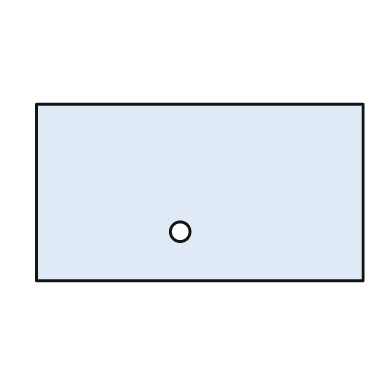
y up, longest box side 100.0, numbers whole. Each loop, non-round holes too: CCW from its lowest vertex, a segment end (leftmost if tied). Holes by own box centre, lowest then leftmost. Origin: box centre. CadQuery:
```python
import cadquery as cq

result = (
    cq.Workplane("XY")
    .moveTo(-50.0, -27.0)
    .lineTo(50.0, -27.0)
    .lineTo(50.0, 27.0)
    .lineTo(-50.0, 27.0)
    .close()
    .moveTo(-6.0, -12.0)
    .circle(3.0)
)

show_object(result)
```